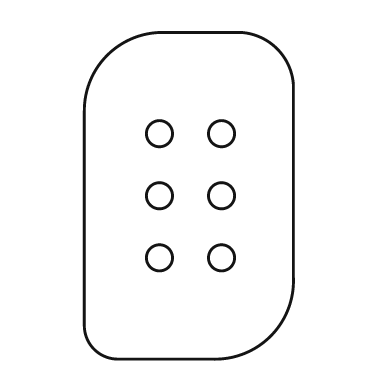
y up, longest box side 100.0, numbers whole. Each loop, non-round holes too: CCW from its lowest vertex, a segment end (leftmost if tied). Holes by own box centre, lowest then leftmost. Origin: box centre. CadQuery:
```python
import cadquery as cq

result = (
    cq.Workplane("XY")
    .moveTo(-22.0, -50.0)
    .lineTo(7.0, -50.0)
    .threePointArc((25.0, -43.0), (32.0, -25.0))
    .lineTo(32.0, 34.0)
    .threePointArc((27.0, 45.0), (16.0, 50.0))
    .lineTo(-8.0, 50.0)
    .threePointArc((-25.0, 43.0), (-32.0, 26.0))
    .lineTo(-32.0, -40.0)
    .threePointArc((-29.0, -47.0), (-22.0, -50.0))
    .close()
    .moveTo(-9.0, -19.0)
    .circle(4.0)
    .moveTo(10.0, -19.0)
    .circle(4.0)
    .moveTo(-9.0, 0.0)
    .circle(4.0)
    .moveTo(10.0, 0.0)
    .circle(4.0)
    .moveTo(-9.0, 19.0)
    .circle(4.0)
    .moveTo(10.0, 19.0)
    .circle(4.0)
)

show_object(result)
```